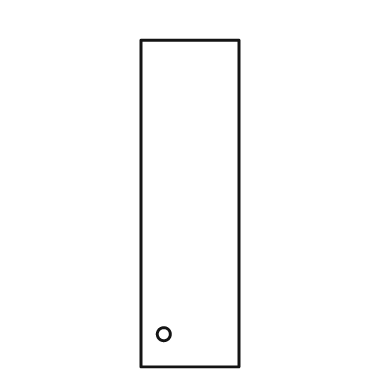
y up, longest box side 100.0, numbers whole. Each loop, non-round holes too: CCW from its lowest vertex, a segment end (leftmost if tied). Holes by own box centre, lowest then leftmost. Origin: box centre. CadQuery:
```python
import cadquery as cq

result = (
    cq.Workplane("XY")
    .moveTo(-15.0, -50.0)
    .lineTo(15.0, -50.0)
    .lineTo(15.0, 50.0)
    .lineTo(-15.0, 50.0)
    .close()
    .moveTo(-8.0, -40.0)
    .circle(2.0)
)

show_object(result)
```